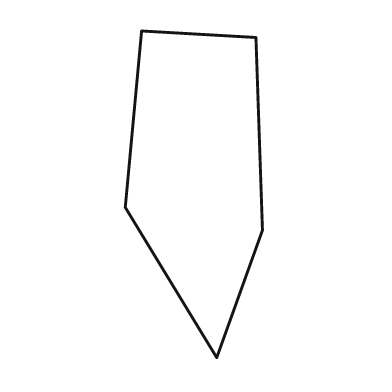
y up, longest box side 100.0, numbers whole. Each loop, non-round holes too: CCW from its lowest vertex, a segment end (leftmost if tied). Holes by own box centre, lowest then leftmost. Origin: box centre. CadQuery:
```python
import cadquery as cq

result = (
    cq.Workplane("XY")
    .moveTo(7.0, -50.0)
    .lineTo(21.0, -11.0)
    .lineTo(19.0, 48.0)
    .lineTo(-16.0, 50.0)
    .lineTo(-21.0, -4.0)
    .close()
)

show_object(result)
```